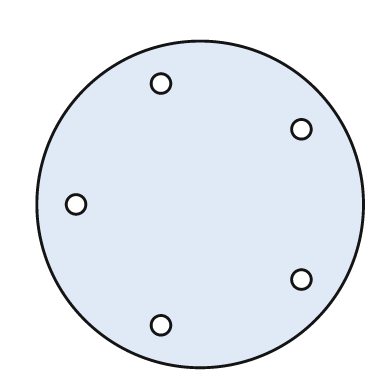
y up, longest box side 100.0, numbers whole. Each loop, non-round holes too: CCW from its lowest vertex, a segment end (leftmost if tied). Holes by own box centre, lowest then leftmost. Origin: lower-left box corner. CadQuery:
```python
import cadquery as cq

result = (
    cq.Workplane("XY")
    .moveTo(50.0, 50.0)
    .circle(50.0)
    .moveTo(38.0, 13.0)
    .circle(3.0)
    .moveTo(81.0, 27.0)
    .circle(3.0)
    .moveTo(12.0, 50.0)
    .circle(3.0)
    .moveTo(81.0, 73.0)
    .circle(3.0)
    .moveTo(38.0, 87.0)
    .circle(3.0)
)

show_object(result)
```